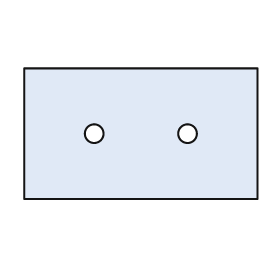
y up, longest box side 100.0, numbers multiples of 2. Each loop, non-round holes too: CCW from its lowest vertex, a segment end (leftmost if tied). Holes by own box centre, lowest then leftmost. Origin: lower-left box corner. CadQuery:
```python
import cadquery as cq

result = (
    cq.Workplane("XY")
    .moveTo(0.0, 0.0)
    .lineTo(100.0, 0.0)
    .lineTo(100.0, 56.0)
    .lineTo(0.0, 56.0)
    .close()
    .moveTo(30.0, 28.0)
    .circle(4.0)
    .moveTo(70.0, 28.0)
    .circle(4.0)
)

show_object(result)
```